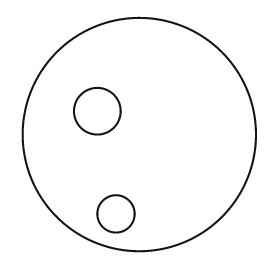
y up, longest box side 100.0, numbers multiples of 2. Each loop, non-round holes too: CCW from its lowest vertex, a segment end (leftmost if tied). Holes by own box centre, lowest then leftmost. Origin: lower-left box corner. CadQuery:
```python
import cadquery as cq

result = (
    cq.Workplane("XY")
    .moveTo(50.0, 50.0)
    .circle(50.0)
    .moveTo(40.0, 16.0)
    .circle(8.0)
    .moveTo(32.0, 60.0)
    .circle(10.0)
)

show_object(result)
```